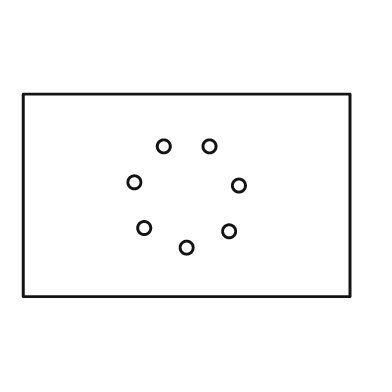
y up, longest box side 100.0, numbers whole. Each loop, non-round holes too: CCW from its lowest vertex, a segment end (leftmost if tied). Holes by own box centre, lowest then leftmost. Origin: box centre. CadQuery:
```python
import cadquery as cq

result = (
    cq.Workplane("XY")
    .moveTo(-50.0, -31.0)
    .lineTo(50.0, -31.0)
    .lineTo(50.0, 31.0)
    .lineTo(-50.0, 31.0)
    .close()
    .moveTo(0.0, -16.0)
    .circle(2.0)
    .moveTo(13.0, -11.0)
    .circle(2.0)
    .moveTo(-13.0, -10.0)
    .circle(2.0)
    .moveTo(16.0, 3.0)
    .circle(2.0)
    .moveTo(-16.0, 4.0)
    .circle(2.0)
    .moveTo(-7.0, 15.0)
    .circle(2.0)
    .moveTo(7.0, 15.0)
    .circle(2.0)
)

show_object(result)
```